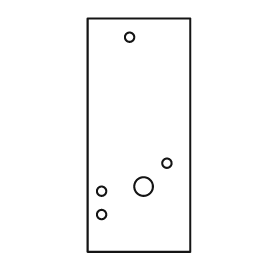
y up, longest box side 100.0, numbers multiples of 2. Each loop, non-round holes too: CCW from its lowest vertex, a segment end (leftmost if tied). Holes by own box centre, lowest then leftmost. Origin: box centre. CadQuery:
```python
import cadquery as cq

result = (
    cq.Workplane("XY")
    .moveTo(-22.0, -50.0)
    .lineTo(22.0, -50.0)
    .lineTo(22.0, 50.0)
    .lineTo(-22.0, 50.0)
    .close()
    .moveTo(-16.0, -34.0)
    .circle(2.0)
    .moveTo(-16.0, -24.0)
    .circle(2.0)
    .moveTo(2.0, -22.0)
    .circle(4.0)
    .moveTo(12.0, -12.0)
    .circle(2.0)
    .moveTo(-4.0, 42.0)
    .circle(2.0)
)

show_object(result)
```